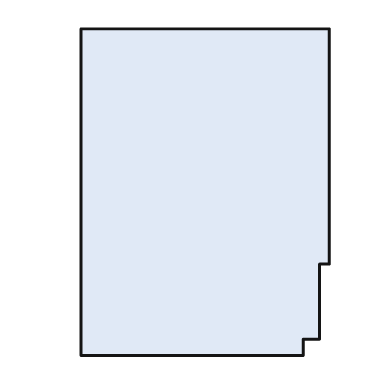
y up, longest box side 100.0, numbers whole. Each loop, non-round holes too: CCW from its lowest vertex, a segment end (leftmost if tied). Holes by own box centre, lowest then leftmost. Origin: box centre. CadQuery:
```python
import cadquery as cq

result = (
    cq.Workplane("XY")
    .moveTo(-38.0, -50.0)
    .lineTo(30.0, -50.0)
    .lineTo(30.0, -45.0)
    .lineTo(35.0, -45.0)
    .lineTo(35.0, -22.0)
    .lineTo(38.0, -22.0)
    .lineTo(38.0, 50.0)
    .lineTo(-38.0, 50.0)
    .close()
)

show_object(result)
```